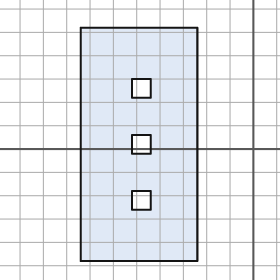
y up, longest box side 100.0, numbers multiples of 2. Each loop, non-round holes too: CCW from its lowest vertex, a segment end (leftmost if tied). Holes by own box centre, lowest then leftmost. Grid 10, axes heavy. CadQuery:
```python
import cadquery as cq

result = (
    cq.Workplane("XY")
    .moveTo(-74.0, -48.0)
    .lineTo(-24.0, -48.0)
    .lineTo(-24.0, 52.0)
    .lineTo(-74.0, 52.0)
    .close()
    .moveTo(-52.0, -26.0)
    .lineTo(-44.0, -26.0)
    .lineTo(-44.0, -18.0)
    .lineTo(-52.0, -18.0)
    .close()
    .moveTo(-52.0, -2.0)
    .lineTo(-44.0, -2.0)
    .lineTo(-44.0, 6.0)
    .lineTo(-52.0, 6.0)
    .close()
    .moveTo(-52.0, 22.0)
    .lineTo(-44.0, 22.0)
    .lineTo(-44.0, 30.0)
    .lineTo(-52.0, 30.0)
    .close()
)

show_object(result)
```